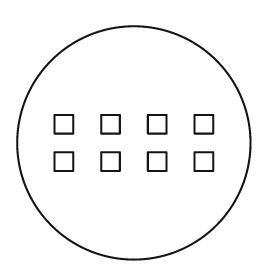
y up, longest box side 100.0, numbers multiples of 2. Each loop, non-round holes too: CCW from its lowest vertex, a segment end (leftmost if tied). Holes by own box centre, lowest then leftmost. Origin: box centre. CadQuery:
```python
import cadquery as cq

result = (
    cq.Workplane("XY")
    .moveTo(0.0, 0.0)
    .circle(50.0)
    .moveTo(-34.0, -12.0)
    .lineTo(-26.0, -12.0)
    .lineTo(-26.0, -4.0)
    .lineTo(-34.0, -4.0)
    .close()
    .moveTo(-14.0, -12.0)
    .lineTo(-6.0, -12.0)
    .lineTo(-6.0, -4.0)
    .lineTo(-14.0, -4.0)
    .close()
    .moveTo(6.0, -12.0)
    .lineTo(14.0, -12.0)
    .lineTo(14.0, -4.0)
    .lineTo(6.0, -4.0)
    .close()
    .moveTo(26.0, -12.0)
    .lineTo(34.0, -12.0)
    .lineTo(34.0, -4.0)
    .lineTo(26.0, -4.0)
    .close()
    .moveTo(-34.0, 4.0)
    .lineTo(-26.0, 4.0)
    .lineTo(-26.0, 12.0)
    .lineTo(-34.0, 12.0)
    .close()
    .moveTo(-14.0, 4.0)
    .lineTo(-6.0, 4.0)
    .lineTo(-6.0, 12.0)
    .lineTo(-14.0, 12.0)
    .close()
    .moveTo(6.0, 4.0)
    .lineTo(14.0, 4.0)
    .lineTo(14.0, 12.0)
    .lineTo(6.0, 12.0)
    .close()
    .moveTo(26.0, 4.0)
    .lineTo(34.0, 4.0)
    .lineTo(34.0, 12.0)
    .lineTo(26.0, 12.0)
    .close()
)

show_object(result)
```